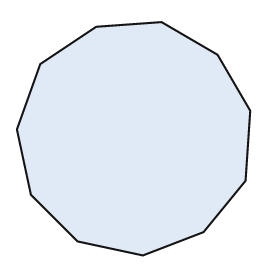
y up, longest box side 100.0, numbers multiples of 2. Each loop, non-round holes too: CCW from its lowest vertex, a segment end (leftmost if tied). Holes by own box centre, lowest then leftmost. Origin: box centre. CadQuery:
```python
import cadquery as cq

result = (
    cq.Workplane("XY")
    .moveTo(4.0, -50.0)
    .lineTo(30.0, -40.0)
    .lineTo(48.0, -18.0)
    .lineTo(50.0, 12.0)
    .lineTo(36.0, 36.0)
    .lineTo(12.0, 50.0)
    .lineTo(-16.0, 48.0)
    .lineTo(-40.0, 32.0)
    .lineTo(-50.0, 4.0)
    .lineTo(-44.0, -24.0)
    .lineTo(-24.0, -44.0)
    .close()
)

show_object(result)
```